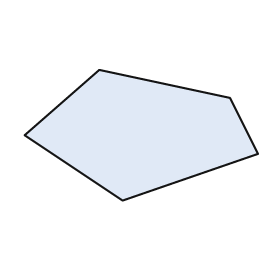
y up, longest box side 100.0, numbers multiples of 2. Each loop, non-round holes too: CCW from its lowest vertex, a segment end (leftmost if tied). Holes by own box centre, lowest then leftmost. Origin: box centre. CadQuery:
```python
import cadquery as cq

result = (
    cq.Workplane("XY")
    .moveTo(-8.0, -28.0)
    .lineTo(50.0, -8.0)
    .lineTo(38.0, 16.0)
    .lineTo(-18.0, 28.0)
    .lineTo(-50.0, 0.0)
    .close()
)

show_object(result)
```